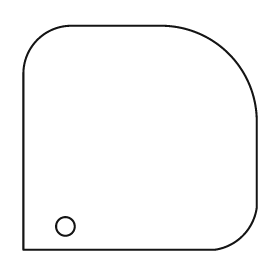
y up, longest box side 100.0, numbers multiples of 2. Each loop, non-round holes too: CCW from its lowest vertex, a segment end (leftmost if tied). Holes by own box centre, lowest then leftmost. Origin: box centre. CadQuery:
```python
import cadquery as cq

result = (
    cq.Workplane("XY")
    .moveTo(-50.0, -48.0)
    .lineTo(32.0, -48.0)
    .threePointArc((44.0, -42.0), (50.0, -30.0))
    .lineTo(50.0, 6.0)
    .threePointArc((38.0, 36.0), (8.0, 48.0))
    .lineTo(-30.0, 48.0)
    .threePointArc((-44.0, 42.0), (-50.0, 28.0))
    .close()
    .moveTo(-32.0, -38.0)
    .circle(4.0)
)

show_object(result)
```